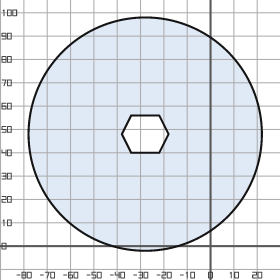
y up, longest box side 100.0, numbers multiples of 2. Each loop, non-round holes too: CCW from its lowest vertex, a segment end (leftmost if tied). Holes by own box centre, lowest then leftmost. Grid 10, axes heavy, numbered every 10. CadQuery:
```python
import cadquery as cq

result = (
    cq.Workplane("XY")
    .moveTo(-28.0, 48.0)
    .circle(50.0)
    .moveTo(-34.0, 40.0)
    .lineTo(-22.0, 40.0)
    .lineTo(-18.0, 48.0)
    .lineTo(-22.0, 56.0)
    .lineTo(-34.0, 56.0)
    .lineTo(-38.0, 48.0)
    .close()
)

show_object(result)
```